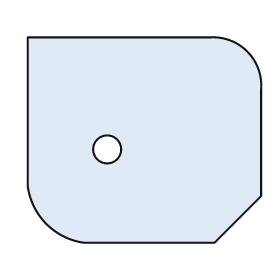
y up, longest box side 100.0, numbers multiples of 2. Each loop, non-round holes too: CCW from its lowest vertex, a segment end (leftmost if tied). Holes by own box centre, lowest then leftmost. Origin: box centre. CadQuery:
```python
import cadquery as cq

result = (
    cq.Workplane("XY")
    .moveTo(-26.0, -44.0)
    .lineTo(30.0, -44.0)
    .lineTo(50.0, -24.0)
    .lineTo(50.0, 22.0)
    .threePointArc((44.0, 38.0), (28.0, 44.0))
    .lineTo(-50.0, 44.0)
    .lineTo(-50.0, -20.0)
    .threePointArc((-42.0, -36.0), (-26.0, -44.0))
    .close()
    .moveTo(-16.0, -4.0)
    .circle(6.0)
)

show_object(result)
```